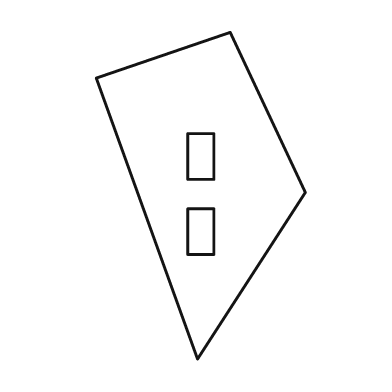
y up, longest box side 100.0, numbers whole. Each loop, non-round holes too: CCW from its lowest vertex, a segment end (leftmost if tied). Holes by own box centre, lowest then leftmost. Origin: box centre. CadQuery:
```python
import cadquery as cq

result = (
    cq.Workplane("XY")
    .moveTo(-1.0, -50.0)
    .lineTo(32.0, 1.0)
    .lineTo(9.0, 50.0)
    .lineTo(-32.0, 36.0)
    .close()
    .moveTo(-4.0, -18.0)
    .lineTo(4.0, -18.0)
    .lineTo(4.0, -4.0)
    .lineTo(-4.0, -4.0)
    .close()
    .moveTo(-4.0, 5.0)
    .lineTo(4.0, 5.0)
    .lineTo(4.0, 19.0)
    .lineTo(-4.0, 19.0)
    .close()
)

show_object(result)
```